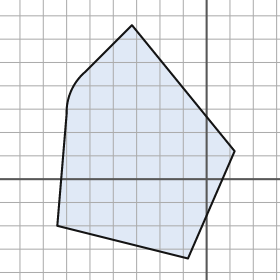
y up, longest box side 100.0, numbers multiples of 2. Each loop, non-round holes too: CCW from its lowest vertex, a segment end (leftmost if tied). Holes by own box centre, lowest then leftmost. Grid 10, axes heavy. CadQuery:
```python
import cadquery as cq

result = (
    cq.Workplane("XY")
    .moveTo(-8.0, -34.0)
    .lineTo(12.0, 12.0)
    .lineTo(-32.0, 66.0)
    .lineTo(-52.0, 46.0)
    .threePointArc((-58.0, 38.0), (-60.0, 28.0))
    .lineTo(-64.0, -20.0)
    .close()
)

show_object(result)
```